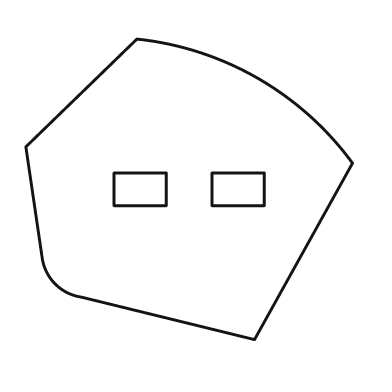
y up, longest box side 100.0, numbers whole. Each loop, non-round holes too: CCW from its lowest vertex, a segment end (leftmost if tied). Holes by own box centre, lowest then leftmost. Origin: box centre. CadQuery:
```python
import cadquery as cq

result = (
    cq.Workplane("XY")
    .moveTo(20.0, -46.0)
    .lineTo(50.0, 8.0)
    .threePointArc((21.0, 34.0), (-16.0, 46.0))
    .lineTo(-50.0, 13.0)
    .lineTo(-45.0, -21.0)
    .threePointArc((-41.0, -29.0), (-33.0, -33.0))
    .close()
    .moveTo(-23.0, -5.0)
    .lineTo(-7.0, -5.0)
    .lineTo(-7.0, 5.0)
    .lineTo(-23.0, 5.0)
    .close()
    .moveTo(7.0, -5.0)
    .lineTo(23.0, -5.0)
    .lineTo(23.0, 5.0)
    .lineTo(7.0, 5.0)
    .close()
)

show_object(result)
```